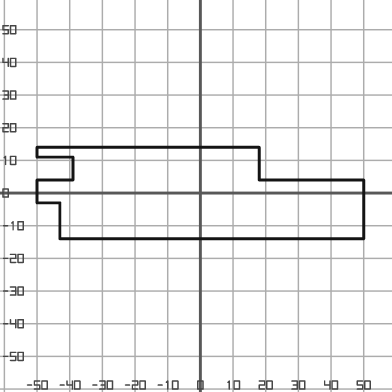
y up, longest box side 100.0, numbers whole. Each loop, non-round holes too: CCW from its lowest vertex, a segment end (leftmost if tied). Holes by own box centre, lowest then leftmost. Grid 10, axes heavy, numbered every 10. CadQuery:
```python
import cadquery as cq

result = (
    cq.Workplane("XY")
    .moveTo(-43.0, -14.0)
    .lineTo(50.0, -14.0)
    .lineTo(50.0, 4.0)
    .lineTo(18.0, 4.0)
    .lineTo(18.0, 14.0)
    .lineTo(-50.0, 14.0)
    .lineTo(-50.0, 11.0)
    .lineTo(-39.0, 11.0)
    .lineTo(-39.0, 4.0)
    .lineTo(-50.0, 4.0)
    .lineTo(-50.0, -3.0)
    .lineTo(-43.0, -3.0)
    .close()
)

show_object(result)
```